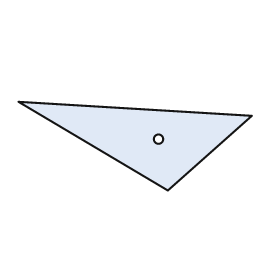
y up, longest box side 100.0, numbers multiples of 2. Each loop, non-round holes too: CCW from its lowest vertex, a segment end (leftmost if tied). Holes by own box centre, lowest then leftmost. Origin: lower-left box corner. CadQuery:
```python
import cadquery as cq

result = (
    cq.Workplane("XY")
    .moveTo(64.0, 0.0)
    .lineTo(100.0, 32.0)
    .lineTo(0.0, 38.0)
    .close()
    .moveTo(60.0, 22.0)
    .circle(2.0)
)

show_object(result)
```